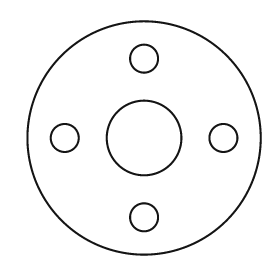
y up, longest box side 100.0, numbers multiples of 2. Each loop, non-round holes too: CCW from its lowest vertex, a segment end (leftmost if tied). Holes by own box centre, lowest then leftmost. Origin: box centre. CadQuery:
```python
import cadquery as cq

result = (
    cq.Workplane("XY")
    .moveTo(0.0, 0.0)
    .circle(50.0)
    .moveTo(0.0, -34.0)
    .circle(6.0)
    .moveTo(-34.0, 0.0)
    .circle(6.0)
    .moveTo(0.0, 0.0)
    .circle(16.0)
    .moveTo(34.0, 0.0)
    .circle(6.0)
    .moveTo(0.0, 34.0)
    .circle(6.0)
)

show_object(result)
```